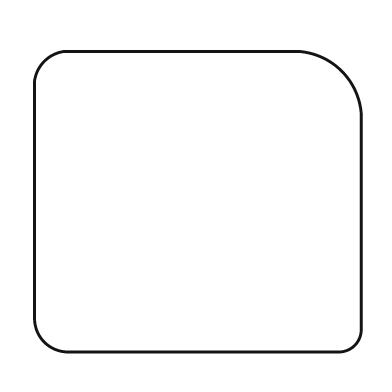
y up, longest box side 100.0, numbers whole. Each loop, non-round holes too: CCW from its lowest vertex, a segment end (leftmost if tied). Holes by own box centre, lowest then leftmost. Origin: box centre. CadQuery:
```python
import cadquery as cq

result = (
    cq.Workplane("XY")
    .moveTo(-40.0, -46.0)
    .lineTo(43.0, -46.0)
    .threePointArc((48.0, -44.0), (50.0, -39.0))
    .lineTo(50.0, 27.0)
    .threePointArc((44.0, 40.0), (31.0, 46.0))
    .lineTo(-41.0, 46.0)
    .threePointArc((-47.0, 43.0), (-50.0, 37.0))
    .lineTo(-50.0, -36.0)
    .threePointArc((-47.0, -43.0), (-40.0, -46.0))
    .close()
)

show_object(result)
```